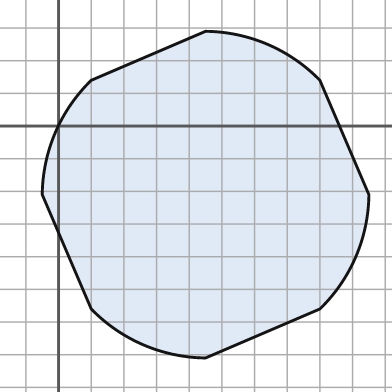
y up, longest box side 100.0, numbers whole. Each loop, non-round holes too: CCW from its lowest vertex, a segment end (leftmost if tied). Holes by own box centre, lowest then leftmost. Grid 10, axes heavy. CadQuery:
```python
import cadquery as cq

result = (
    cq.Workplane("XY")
    .moveTo(45.0, -71.0)
    .lineTo(80.0, -56.0)
    .threePointArc((91.0, -40.0), (95.0, -21.0))
    .lineTo(80.0, 14.0)
    .threePointArc((64.0, 25.0), (45.0, 29.0))
    .lineTo(10.0, 14.0)
    .threePointArc((-1.0, -2.0), (-5.0, -21.0))
    .lineTo(10.0, -56.0)
    .threePointArc((26.0, -67.0), (45.0, -71.0))
    .close()
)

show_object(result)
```